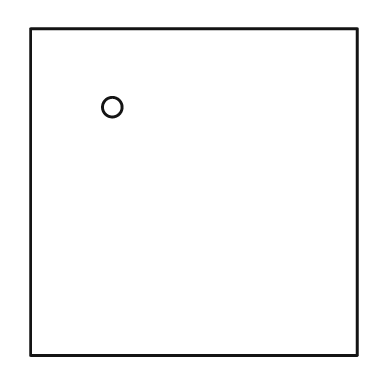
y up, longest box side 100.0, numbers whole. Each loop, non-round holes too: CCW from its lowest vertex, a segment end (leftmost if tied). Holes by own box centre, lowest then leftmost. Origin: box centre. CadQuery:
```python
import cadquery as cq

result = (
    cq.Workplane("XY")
    .moveTo(-50.0, -50.0)
    .lineTo(50.0, -50.0)
    .lineTo(50.0, 50.0)
    .lineTo(-50.0, 50.0)
    .close()
    .moveTo(-25.0, 26.0)
    .circle(3.0)
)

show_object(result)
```